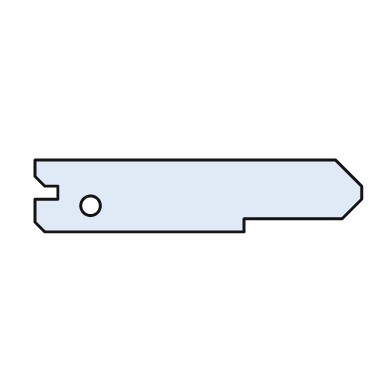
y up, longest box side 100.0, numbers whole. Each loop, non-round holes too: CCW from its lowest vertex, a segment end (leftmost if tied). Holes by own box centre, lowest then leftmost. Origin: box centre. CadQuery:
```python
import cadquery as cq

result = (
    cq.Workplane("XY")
    .moveTo(-47.0, -11.0)
    .lineTo(14.0, -11.0)
    .lineTo(14.0, -7.0)
    .lineTo(44.0, -7.0)
    .lineTo(50.0, -1.0)
    .lineTo(50.0, 3.0)
    .lineTo(42.0, 11.0)
    .lineTo(-50.0, 11.0)
    .lineTo(-50.0, 6.0)
    .lineTo(-47.0, 3.0)
    .lineTo(-43.0, 3.0)
    .lineTo(-43.0, -1.0)
    .lineTo(-50.0, -1.0)
    .lineTo(-50.0, -8.0)
    .close()
    .moveTo(-33.0, -3.0)
    .circle(3.0)
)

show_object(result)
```